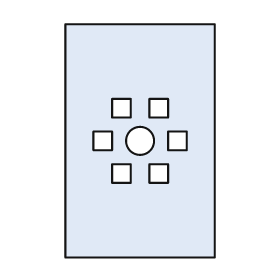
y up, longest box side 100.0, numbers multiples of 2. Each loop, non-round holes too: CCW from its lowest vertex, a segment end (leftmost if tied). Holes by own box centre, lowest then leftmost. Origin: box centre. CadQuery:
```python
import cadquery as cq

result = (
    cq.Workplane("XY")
    .moveTo(-32.0, -50.0)
    .lineTo(32.0, -50.0)
    .lineTo(32.0, 50.0)
    .lineTo(-32.0, 50.0)
    .close()
    .moveTo(-12.0, -18.0)
    .lineTo(-4.0, -18.0)
    .lineTo(-4.0, -10.0)
    .lineTo(-12.0, -10.0)
    .close()
    .moveTo(4.0, -18.0)
    .lineTo(12.0, -18.0)
    .lineTo(12.0, -10.0)
    .lineTo(4.0, -10.0)
    .close()
    .moveTo(-20.0, -4.0)
    .lineTo(-12.0, -4.0)
    .lineTo(-12.0, 4.0)
    .lineTo(-20.0, 4.0)
    .close()
    .moveTo(0.0, 0.0)
    .circle(6.0)
    .moveTo(12.0, -4.0)
    .lineTo(20.0, -4.0)
    .lineTo(20.0, 4.0)
    .lineTo(12.0, 4.0)
    .close()
    .moveTo(-12.0, 10.0)
    .lineTo(-4.0, 10.0)
    .lineTo(-4.0, 18.0)
    .lineTo(-12.0, 18.0)
    .close()
    .moveTo(4.0, 10.0)
    .lineTo(12.0, 10.0)
    .lineTo(12.0, 18.0)
    .lineTo(4.0, 18.0)
    .close()
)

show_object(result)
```